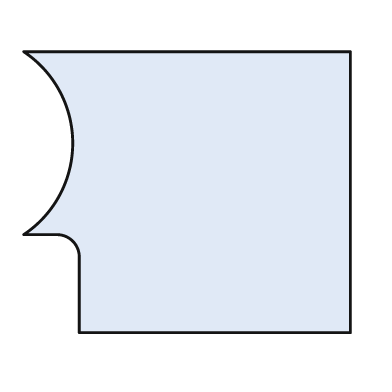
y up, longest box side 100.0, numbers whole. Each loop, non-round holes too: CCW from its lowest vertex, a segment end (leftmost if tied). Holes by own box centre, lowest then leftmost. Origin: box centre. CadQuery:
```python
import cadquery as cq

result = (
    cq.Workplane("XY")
    .moveTo(-33.0, -43.0)
    .lineTo(50.0, -43.0)
    .lineTo(50.0, 43.0)
    .lineTo(-50.0, 43.0)
    .threePointArc((-35.0, 15.0), (-50.0, -13.0))
    .lineTo(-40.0, -13.0)
    .threePointArc((-35.0, -15.0), (-33.0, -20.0))
    .close()
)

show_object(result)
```